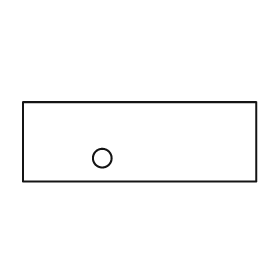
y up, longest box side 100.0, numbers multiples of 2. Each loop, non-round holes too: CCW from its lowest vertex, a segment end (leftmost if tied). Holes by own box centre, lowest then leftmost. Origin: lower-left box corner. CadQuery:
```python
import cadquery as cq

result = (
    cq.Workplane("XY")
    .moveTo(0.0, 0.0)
    .lineTo(100.0, 0.0)
    .lineTo(100.0, 34.0)
    .lineTo(0.0, 34.0)
    .close()
    .moveTo(34.0, 10.0)
    .circle(4.0)
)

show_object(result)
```